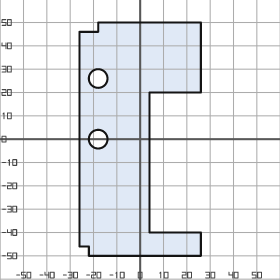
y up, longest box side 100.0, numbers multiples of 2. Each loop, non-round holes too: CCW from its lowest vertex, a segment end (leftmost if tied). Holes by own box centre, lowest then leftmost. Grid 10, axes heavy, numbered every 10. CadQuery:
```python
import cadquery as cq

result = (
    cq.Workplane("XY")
    .moveTo(-22.0, -50.0)
    .lineTo(26.0, -50.0)
    .lineTo(26.0, -40.0)
    .lineTo(4.0, -40.0)
    .lineTo(4.0, 20.0)
    .lineTo(26.0, 20.0)
    .lineTo(26.0, 50.0)
    .lineTo(-18.0, 50.0)
    .lineTo(-18.0, 46.0)
    .lineTo(-26.0, 46.0)
    .lineTo(-26.0, -46.0)
    .lineTo(-22.0, -46.0)
    .close()
    .moveTo(-18.0, 0.0)
    .circle(4.0)
    .moveTo(-18.0, 26.0)
    .circle(4.0)
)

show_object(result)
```